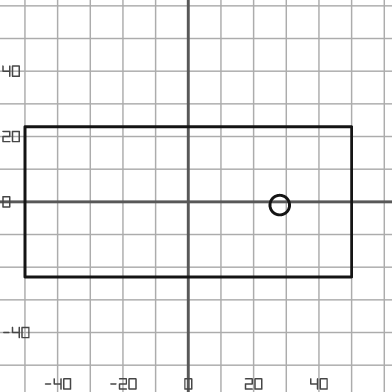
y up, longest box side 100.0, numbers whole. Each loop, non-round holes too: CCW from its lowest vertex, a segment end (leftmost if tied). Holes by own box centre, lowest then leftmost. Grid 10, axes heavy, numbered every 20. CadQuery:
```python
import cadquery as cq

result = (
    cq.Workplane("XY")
    .moveTo(-50.0, -23.0)
    .lineTo(50.0, -23.0)
    .lineTo(50.0, 23.0)
    .lineTo(-50.0, 23.0)
    .close()
    .moveTo(28.0, -1.0)
    .circle(3.0)
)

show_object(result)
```